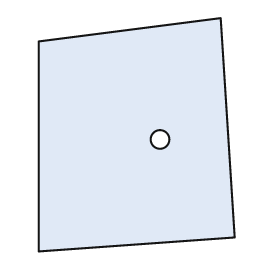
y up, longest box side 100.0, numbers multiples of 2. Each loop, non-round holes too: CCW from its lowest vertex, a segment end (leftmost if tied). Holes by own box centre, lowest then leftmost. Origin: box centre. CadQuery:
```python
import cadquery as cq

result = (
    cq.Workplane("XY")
    .moveTo(-42.0, -50.0)
    .lineTo(42.0, -44.0)
    .lineTo(36.0, 50.0)
    .lineTo(-42.0, 40.0)
    .close()
    .moveTo(10.0, -2.0)
    .circle(4.0)
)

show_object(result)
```